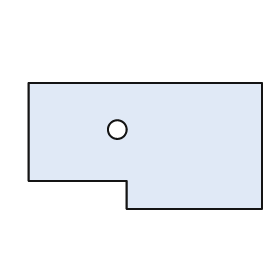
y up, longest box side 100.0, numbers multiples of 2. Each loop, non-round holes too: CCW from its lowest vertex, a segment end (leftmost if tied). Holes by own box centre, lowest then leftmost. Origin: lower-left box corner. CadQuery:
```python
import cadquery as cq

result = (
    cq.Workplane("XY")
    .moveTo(42.0, 0.0)
    .lineTo(100.0, 0.0)
    .lineTo(100.0, 54.0)
    .lineTo(0.0, 54.0)
    .lineTo(0.0, 12.0)
    .lineTo(42.0, 12.0)
    .close()
    .moveTo(38.0, 34.0)
    .circle(4.0)
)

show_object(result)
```